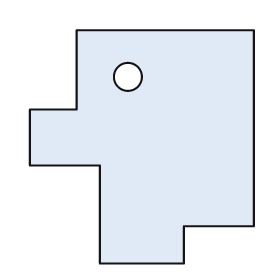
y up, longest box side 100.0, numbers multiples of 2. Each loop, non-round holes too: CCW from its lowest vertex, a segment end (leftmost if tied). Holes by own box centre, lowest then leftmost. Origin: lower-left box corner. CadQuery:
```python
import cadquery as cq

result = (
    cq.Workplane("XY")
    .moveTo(30.0, 0.0)
    .lineTo(66.0, 0.0)
    .lineTo(66.0, 16.0)
    .lineTo(96.0, 16.0)
    .lineTo(96.0, 100.0)
    .lineTo(20.0, 100.0)
    .lineTo(20.0, 66.0)
    .lineTo(0.0, 66.0)
    .lineTo(0.0, 42.0)
    .lineTo(30.0, 42.0)
    .close()
    .moveTo(42.0, 80.0)
    .circle(6.0)
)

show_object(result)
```